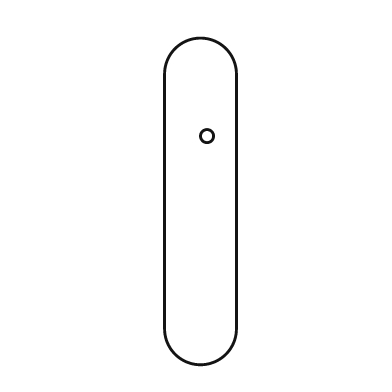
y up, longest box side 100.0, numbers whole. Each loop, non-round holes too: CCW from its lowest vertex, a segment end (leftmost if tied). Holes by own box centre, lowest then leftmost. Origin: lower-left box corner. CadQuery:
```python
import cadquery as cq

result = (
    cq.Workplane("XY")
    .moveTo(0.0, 11.0)
    .threePointArc((11.0, 0.0), (22.0, 11.0))
    .lineTo(22.0, 89.0)
    .threePointArc((11.0, 100.0), (0.0, 89.0))
    .close()
    .moveTo(13.0, 70.0)
    .circle(2.0)
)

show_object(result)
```